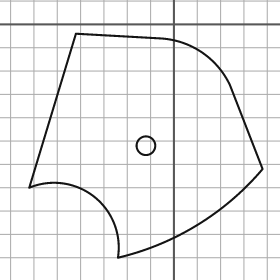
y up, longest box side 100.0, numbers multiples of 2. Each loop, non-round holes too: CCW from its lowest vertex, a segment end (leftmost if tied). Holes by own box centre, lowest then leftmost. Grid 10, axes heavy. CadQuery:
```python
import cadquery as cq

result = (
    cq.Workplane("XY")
    .moveTo(-24.0, -100.0)
    .threePointArc((10.0, -86.0), (38.0, -62.0))
    .lineTo(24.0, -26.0)
    .threePointArc((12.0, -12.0), (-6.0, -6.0))
    .lineTo(-42.0, -4.0)
    .lineTo(-62.0, -70.0)
    .threePointArc((-34.0, -74.0), (-24.0, -100.0))
    .close()
    .moveTo(-12.0, -52.0)
    .circle(4.0)
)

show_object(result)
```